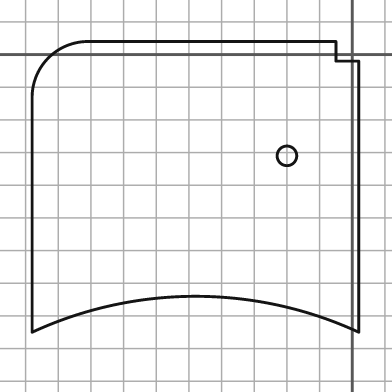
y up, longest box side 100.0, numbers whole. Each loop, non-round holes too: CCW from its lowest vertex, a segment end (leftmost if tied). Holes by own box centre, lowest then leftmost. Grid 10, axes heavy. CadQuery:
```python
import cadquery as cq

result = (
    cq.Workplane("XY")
    .moveTo(-98.0, -85.0)
    .threePointArc((-48.0, -74.0), (2.0, -85.0))
    .lineTo(2.0, -2.0)
    .lineTo(-5.0, -2.0)
    .lineTo(-5.0, 4.0)
    .lineTo(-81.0, 4.0)
    .threePointArc((-93.0, -1.0), (-98.0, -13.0))
    .close()
    .moveTo(-20.0, -31.0)
    .circle(3.0)
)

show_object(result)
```